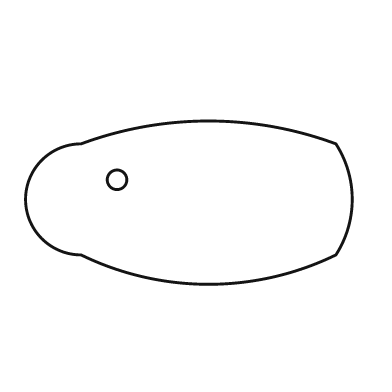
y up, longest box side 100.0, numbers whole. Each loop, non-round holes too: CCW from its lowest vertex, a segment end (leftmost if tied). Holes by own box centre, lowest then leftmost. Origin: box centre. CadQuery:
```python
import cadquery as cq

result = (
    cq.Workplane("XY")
    .moveTo(-33.0, -16.0)
    .threePointArc((6.0, -25.0), (45.0, -16.0))
    .threePointArc((50.0, 1.0), (45.0, 18.0))
    .threePointArc((6.0, 25.0), (-33.0, 18.0))
    .threePointArc((-50.0, 1.0), (-33.0, -16.0))
    .close()
    .moveTo(-22.0, 7.0)
    .circle(3.0)
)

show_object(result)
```